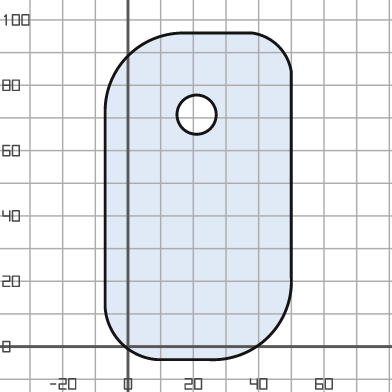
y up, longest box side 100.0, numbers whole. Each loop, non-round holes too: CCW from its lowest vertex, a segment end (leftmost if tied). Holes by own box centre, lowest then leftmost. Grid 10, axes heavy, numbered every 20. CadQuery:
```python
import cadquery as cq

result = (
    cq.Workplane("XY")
    .moveTo(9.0, -4.0)
    .lineTo(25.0, -4.0)
    .threePointArc((43.0, 3.0), (50.0, 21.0))
    .lineTo(50.0, 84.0)
    .threePointArc((46.0, 92.0), (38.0, 96.0))
    .lineTo(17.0, 96.0)
    .threePointArc((0.0, 89.0), (-7.0, 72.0))
    .lineTo(-7.0, 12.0)
    .threePointArc((-2.0, 1.0), (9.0, -4.0))
    .close()
    .moveTo(21.0, 71.0)
    .circle(6.0)
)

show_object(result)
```